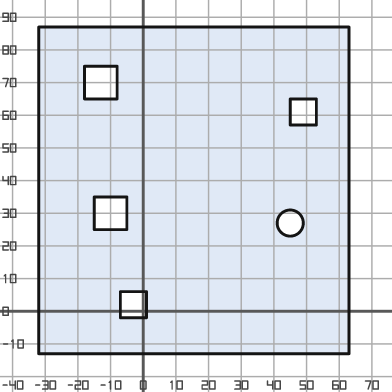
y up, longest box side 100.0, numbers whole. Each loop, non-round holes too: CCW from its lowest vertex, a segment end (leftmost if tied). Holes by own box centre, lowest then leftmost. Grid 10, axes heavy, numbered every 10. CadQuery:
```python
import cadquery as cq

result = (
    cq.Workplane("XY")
    .moveTo(-32.0, -13.0)
    .lineTo(63.0, -13.0)
    .lineTo(63.0, 87.0)
    .lineTo(-32.0, 87.0)
    .close()
    .moveTo(-7.0, -2.0)
    .lineTo(1.0, -2.0)
    .lineTo(1.0, 6.0)
    .lineTo(-7.0, 6.0)
    .close()
    .moveTo(45.0, 27.0)
    .circle(4.0)
    .moveTo(-15.0, 25.0)
    .lineTo(-5.0, 25.0)
    .lineTo(-5.0, 35.0)
    .lineTo(-15.0, 35.0)
    .close()
    .moveTo(45.0, 57.0)
    .lineTo(53.0, 57.0)
    .lineTo(53.0, 65.0)
    .lineTo(45.0, 65.0)
    .close()
    .moveTo(-18.0, 65.0)
    .lineTo(-8.0, 65.0)
    .lineTo(-8.0, 75.0)
    .lineTo(-18.0, 75.0)
    .close()
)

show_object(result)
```